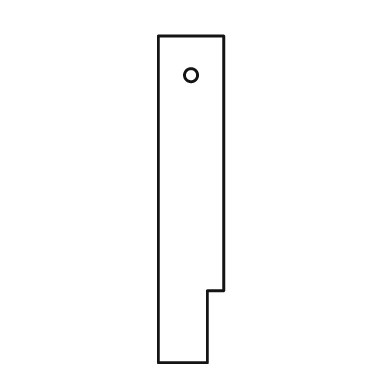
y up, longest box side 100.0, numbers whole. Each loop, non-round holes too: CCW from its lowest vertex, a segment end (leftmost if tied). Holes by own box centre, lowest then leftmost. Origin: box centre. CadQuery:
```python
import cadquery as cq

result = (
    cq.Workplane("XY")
    .moveTo(-10.0, -50.0)
    .lineTo(5.0, -50.0)
    .lineTo(5.0, -28.0)
    .lineTo(10.0, -28.0)
    .lineTo(10.0, 50.0)
    .lineTo(-10.0, 50.0)
    .close()
    .moveTo(0.0, 38.0)
    .circle(2.0)
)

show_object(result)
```